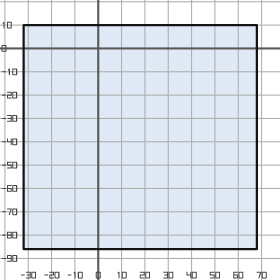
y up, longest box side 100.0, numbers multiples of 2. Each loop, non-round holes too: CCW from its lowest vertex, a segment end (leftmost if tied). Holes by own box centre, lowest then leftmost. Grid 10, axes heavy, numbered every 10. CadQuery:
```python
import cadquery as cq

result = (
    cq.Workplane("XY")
    .moveTo(-32.0, -86.0)
    .lineTo(68.0, -86.0)
    .lineTo(68.0, 10.0)
    .lineTo(-32.0, 10.0)
    .close()
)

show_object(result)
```